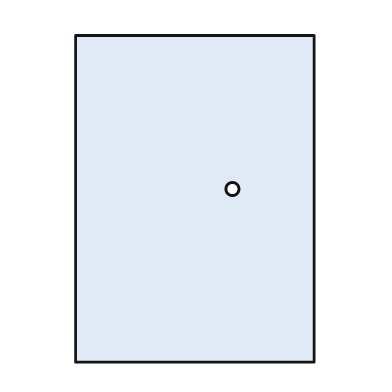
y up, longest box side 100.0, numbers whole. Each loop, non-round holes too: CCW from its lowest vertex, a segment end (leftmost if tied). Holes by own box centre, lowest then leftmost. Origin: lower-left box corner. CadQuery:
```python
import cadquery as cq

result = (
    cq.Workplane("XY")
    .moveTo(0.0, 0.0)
    .lineTo(73.0, 0.0)
    .lineTo(73.0, 100.0)
    .lineTo(0.0, 100.0)
    .close()
    .moveTo(48.0, 53.0)
    .circle(2.0)
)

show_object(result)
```